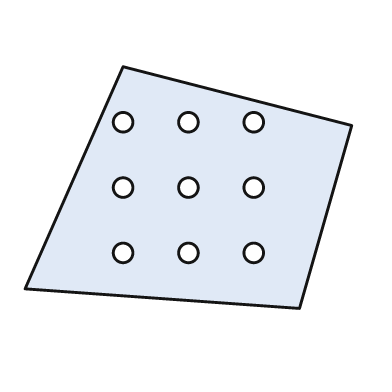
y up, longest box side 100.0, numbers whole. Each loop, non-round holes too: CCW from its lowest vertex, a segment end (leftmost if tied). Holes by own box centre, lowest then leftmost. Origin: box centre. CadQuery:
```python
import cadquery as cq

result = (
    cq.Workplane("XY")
    .moveTo(34.0, -37.0)
    .lineTo(50.0, 19.0)
    .lineTo(-20.0, 37.0)
    .lineTo(-50.0, -31.0)
    .close()
    .moveTo(-20.0, -20.0)
    .circle(3.0)
    .moveTo(0.0, -20.0)
    .circle(3.0)
    .moveTo(20.0, -20.0)
    .circle(3.0)
    .moveTo(-20.0, 0.0)
    .circle(3.0)
    .moveTo(0.0, 0.0)
    .circle(3.0)
    .moveTo(20.0, 0.0)
    .circle(3.0)
    .moveTo(-20.0, 20.0)
    .circle(3.0)
    .moveTo(0.0, 20.0)
    .circle(3.0)
    .moveTo(20.0, 20.0)
    .circle(3.0)
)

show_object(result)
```